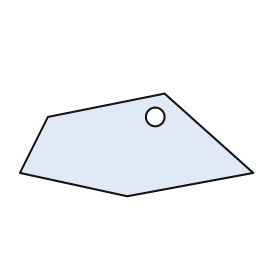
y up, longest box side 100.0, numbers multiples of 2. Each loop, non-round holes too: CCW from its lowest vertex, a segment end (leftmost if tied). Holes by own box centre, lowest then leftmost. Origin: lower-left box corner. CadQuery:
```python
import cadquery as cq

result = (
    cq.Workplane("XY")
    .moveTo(46.0, 0.0)
    .lineTo(100.0, 10.0)
    .lineTo(62.0, 44.0)
    .lineTo(12.0, 34.0)
    .lineTo(0.0, 10.0)
    .close()
    .moveTo(58.0, 34.0)
    .circle(4.0)
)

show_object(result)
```